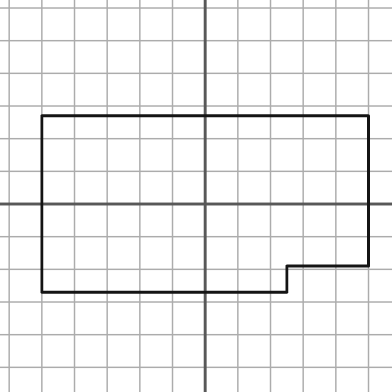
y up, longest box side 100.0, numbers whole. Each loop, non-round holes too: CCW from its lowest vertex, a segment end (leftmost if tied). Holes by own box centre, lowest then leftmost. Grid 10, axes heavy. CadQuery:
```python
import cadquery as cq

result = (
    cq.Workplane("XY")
    .moveTo(-50.0, -27.0)
    .lineTo(25.0, -27.0)
    .lineTo(25.0, -19.0)
    .lineTo(50.0, -19.0)
    .lineTo(50.0, 27.0)
    .lineTo(-50.0, 27.0)
    .close()
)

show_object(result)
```